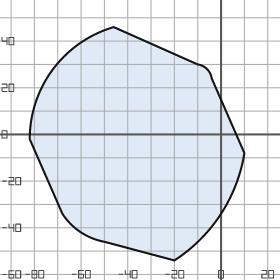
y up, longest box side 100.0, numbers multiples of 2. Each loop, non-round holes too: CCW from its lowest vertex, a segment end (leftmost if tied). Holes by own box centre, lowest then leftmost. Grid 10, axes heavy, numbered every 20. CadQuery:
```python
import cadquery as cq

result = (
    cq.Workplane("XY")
    .moveTo(-20.0, -54.0)
    .threePointArc((0.0, -34.0), (10.0, -8.0))
    .lineTo(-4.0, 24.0)
    .threePointArc((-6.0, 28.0), (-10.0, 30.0))
    .lineTo(-46.0, 46.0)
    .threePointArc((-72.0, 28.0), (-82.0, -2.0))
    .lineTo(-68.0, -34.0)
    .threePointArc((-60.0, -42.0), (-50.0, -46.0))
    .close()
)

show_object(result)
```